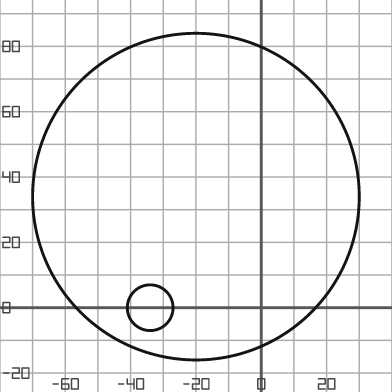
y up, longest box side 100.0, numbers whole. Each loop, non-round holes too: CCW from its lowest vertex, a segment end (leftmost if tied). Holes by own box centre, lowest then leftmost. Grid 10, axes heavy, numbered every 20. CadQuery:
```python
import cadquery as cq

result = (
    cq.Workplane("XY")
    .moveTo(-20.0, 34.0)
    .circle(50.0)
    .moveTo(-34.0, 0.0)
    .circle(7.0)
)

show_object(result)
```